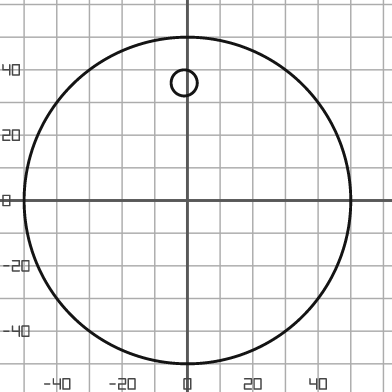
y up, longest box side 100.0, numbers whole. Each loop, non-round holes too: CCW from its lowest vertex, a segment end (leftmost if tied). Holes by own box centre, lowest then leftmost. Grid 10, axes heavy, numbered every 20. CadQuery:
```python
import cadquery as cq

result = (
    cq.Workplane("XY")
    .moveTo(0.0, 0.0)
    .circle(50.0)
    .moveTo(-1.0, 36.0)
    .circle(4.0)
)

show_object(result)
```